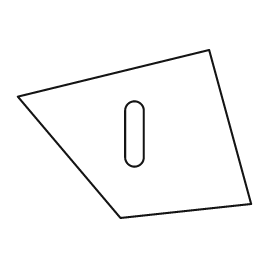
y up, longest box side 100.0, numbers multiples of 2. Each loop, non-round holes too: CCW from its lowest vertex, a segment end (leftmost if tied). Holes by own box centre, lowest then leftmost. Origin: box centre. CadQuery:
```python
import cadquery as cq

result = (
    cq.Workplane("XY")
    .moveTo(-6.0, -36.0)
    .lineTo(50.0, -30.0)
    .lineTo(32.0, 36.0)
    .lineTo(-50.0, 16.0)
    .close()
    .moveTo(-4.0, -10.0)
    .threePointArc((0.0, -14.0), (4.0, -10.0))
    .lineTo(4.0, 10.0)
    .threePointArc((0.0, 14.0), (-4.0, 10.0))
    .close()
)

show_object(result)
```